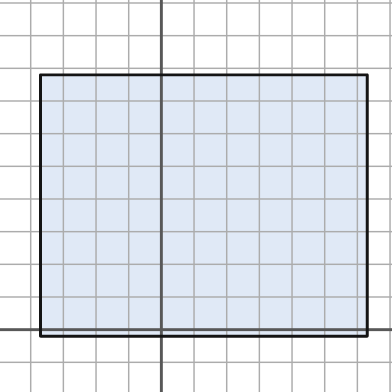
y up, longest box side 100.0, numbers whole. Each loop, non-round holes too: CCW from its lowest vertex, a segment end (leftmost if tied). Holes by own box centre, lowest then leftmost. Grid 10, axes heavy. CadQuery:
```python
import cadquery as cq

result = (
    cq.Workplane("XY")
    .moveTo(-37.0, -2.0)
    .lineTo(63.0, -2.0)
    .lineTo(63.0, 78.0)
    .lineTo(-37.0, 78.0)
    .close()
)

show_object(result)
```